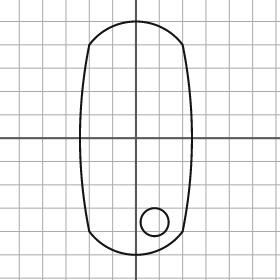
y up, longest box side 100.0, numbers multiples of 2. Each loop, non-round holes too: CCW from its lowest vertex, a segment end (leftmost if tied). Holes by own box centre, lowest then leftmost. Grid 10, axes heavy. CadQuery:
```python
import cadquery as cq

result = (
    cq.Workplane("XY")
    .moveTo(-20.0, -40.0)
    .threePointArc((0.0, -50.0), (20.0, -40.0))
    .threePointArc((24.0, 0.0), (20.0, 40.0))
    .threePointArc((0.0, 50.0), (-20.0, 40.0))
    .threePointArc((-24.0, 0.0), (-20.0, -40.0))
    .close()
    .moveTo(8.0, -36.0)
    .circle(6.0)
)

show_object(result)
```